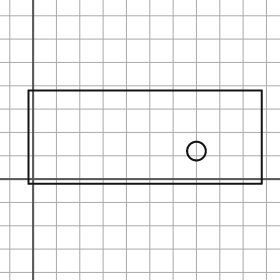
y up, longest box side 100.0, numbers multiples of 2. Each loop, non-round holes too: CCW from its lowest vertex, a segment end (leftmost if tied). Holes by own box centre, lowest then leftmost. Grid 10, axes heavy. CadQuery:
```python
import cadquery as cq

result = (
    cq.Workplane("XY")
    .moveTo(-2.0, -2.0)
    .lineTo(98.0, -2.0)
    .lineTo(98.0, 38.0)
    .lineTo(-2.0, 38.0)
    .close()
    .moveTo(70.0, 12.0)
    .circle(4.0)
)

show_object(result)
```